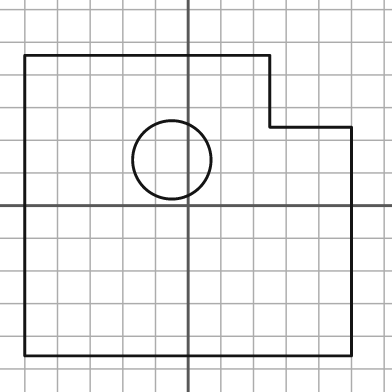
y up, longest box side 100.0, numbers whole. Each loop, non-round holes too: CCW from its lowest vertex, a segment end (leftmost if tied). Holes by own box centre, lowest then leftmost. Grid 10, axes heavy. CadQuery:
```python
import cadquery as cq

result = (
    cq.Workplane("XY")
    .moveTo(-50.0, -46.0)
    .lineTo(50.0, -46.0)
    .lineTo(50.0, 24.0)
    .lineTo(25.0, 24.0)
    .lineTo(25.0, 46.0)
    .lineTo(-50.0, 46.0)
    .close()
    .moveTo(-5.0, 14.0)
    .circle(12.0)
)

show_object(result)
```